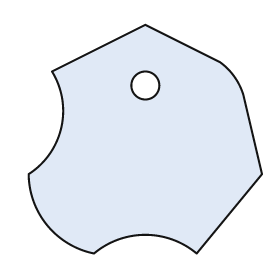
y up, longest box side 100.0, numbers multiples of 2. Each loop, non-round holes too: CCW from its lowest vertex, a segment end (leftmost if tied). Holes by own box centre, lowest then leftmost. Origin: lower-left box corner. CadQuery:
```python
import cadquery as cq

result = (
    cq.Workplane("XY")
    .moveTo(28.0, 0.0)
    .threePointArc((50.0, 8.0), (72.0, 0.0))
    .lineTo(100.0, 34.0)
    .lineTo(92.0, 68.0)
    .threePointArc((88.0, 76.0), (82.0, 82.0))
    .lineTo(50.0, 98.0)
    .lineTo(10.0, 78.0)
    .threePointArc((14.0, 54.0), (0.0, 34.0))
    .threePointArc((8.0, 12.0), (28.0, 0.0))
    .close()
    .moveTo(50.0, 72.0)
    .circle(6.0)
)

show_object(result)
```